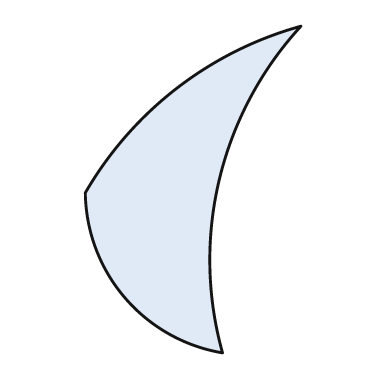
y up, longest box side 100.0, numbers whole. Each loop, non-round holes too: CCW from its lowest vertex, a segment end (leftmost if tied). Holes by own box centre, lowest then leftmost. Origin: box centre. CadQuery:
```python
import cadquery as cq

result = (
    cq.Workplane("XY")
    .moveTo(9.0, -50.0)
    .threePointArc((8.0, 3.0), (33.0, 50.0))
    .threePointArc((-5.0, 31.0), (-33.0, -1.0))
    .threePointArc((-21.0, -33.0), (9.0, -50.0))
    .close()
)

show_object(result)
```